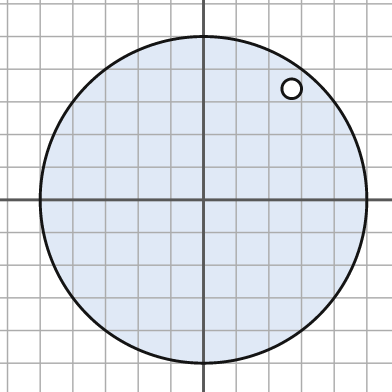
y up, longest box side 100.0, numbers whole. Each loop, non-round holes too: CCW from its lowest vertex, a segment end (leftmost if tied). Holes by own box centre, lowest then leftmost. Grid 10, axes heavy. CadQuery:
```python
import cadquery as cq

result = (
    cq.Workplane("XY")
    .moveTo(0.0, 0.0)
    .circle(50.0)
    .moveTo(27.0, 34.0)
    .circle(3.0)
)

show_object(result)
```